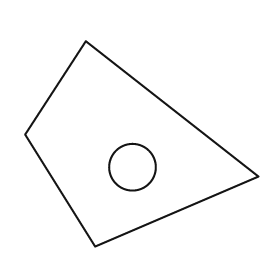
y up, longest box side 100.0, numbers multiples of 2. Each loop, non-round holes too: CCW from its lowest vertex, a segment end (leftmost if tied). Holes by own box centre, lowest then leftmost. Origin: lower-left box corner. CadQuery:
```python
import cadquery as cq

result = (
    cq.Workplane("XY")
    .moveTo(30.0, 0.0)
    .lineTo(100.0, 30.0)
    .lineTo(26.0, 88.0)
    .lineTo(0.0, 48.0)
    .close()
    .moveTo(46.0, 34.0)
    .circle(10.0)
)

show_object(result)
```